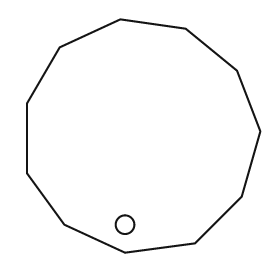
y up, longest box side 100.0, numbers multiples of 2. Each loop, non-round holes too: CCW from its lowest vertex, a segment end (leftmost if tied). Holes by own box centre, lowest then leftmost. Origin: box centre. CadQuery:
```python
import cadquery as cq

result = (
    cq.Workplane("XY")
    .moveTo(-8.0, -50.0)
    .lineTo(22.0, -46.0)
    .lineTo(42.0, -26.0)
    .lineTo(50.0, 2.0)
    .lineTo(40.0, 28.0)
    .lineTo(18.0, 46.0)
    .lineTo(-10.0, 50.0)
    .lineTo(-36.0, 38.0)
    .lineTo(-50.0, 14.0)
    .lineTo(-50.0, -16.0)
    .lineTo(-34.0, -38.0)
    .close()
    .moveTo(-8.0, -38.0)
    .circle(4.0)
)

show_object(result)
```